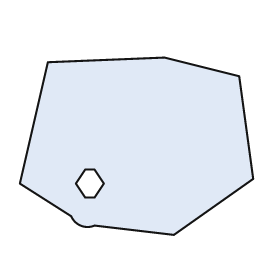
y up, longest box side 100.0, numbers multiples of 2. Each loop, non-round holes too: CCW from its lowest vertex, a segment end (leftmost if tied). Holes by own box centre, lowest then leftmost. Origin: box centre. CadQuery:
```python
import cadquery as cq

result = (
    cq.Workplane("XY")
    .moveTo(16.0, -38.0)
    .lineTo(50.0, -14.0)
    .lineTo(44.0, 30.0)
    .lineTo(12.0, 38.0)
    .lineTo(-38.0, 36.0)
    .lineTo(-50.0, -16.0)
    .lineTo(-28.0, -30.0)
    .threePointArc((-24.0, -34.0), (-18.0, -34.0))
    .close()
    .moveTo(-22.0, -22.0)
    .lineTo(-18.0, -22.0)
    .lineTo(-14.0, -16.0)
    .lineTo(-18.0, -10.0)
    .lineTo(-22.0, -10.0)
    .lineTo(-26.0, -16.0)
    .close()
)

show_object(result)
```